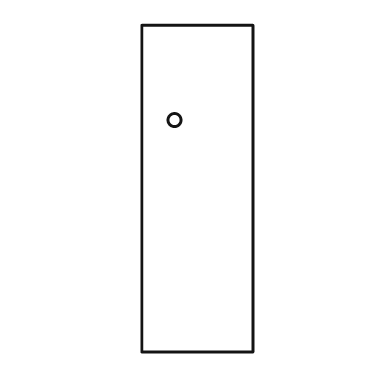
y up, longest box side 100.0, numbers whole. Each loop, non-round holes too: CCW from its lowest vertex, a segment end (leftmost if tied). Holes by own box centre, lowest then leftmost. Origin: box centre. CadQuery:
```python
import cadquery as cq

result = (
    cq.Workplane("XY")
    .moveTo(-17.0, -50.0)
    .lineTo(17.0, -50.0)
    .lineTo(17.0, 50.0)
    .lineTo(-17.0, 50.0)
    .close()
    .moveTo(-7.0, 21.0)
    .circle(2.0)
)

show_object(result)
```